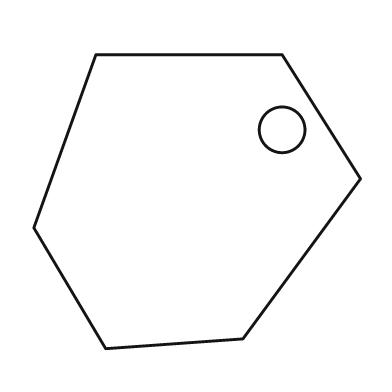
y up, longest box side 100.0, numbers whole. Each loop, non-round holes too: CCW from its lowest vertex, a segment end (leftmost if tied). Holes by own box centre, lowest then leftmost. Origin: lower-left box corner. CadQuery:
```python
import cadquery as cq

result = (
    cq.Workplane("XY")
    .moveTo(22.0, 0.0)
    .lineTo(64.0, 3.0)
    .lineTo(100.0, 52.0)
    .lineTo(76.0, 90.0)
    .lineTo(19.0, 90.0)
    .lineTo(0.0, 37.0)
    .close()
    .moveTo(76.0, 67.0)
    .circle(7.0)
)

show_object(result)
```